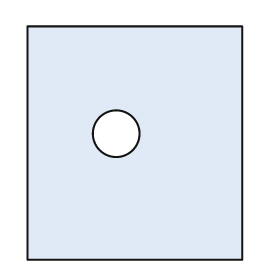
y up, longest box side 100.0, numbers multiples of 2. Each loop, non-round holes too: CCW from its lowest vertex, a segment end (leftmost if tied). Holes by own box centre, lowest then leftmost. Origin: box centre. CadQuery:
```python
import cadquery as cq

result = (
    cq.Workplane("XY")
    .moveTo(-46.0, -50.0)
    .lineTo(46.0, -50.0)
    .lineTo(46.0, 50.0)
    .lineTo(-46.0, 50.0)
    .close()
    .moveTo(-8.0, 4.0)
    .circle(10.0)
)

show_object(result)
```